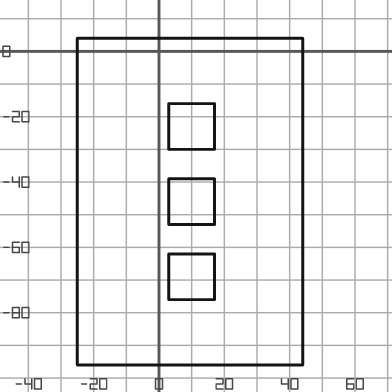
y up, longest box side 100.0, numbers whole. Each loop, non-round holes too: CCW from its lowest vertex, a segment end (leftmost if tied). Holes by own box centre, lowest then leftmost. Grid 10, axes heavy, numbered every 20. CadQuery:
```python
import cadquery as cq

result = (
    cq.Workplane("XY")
    .moveTo(-25.0, -96.0)
    .lineTo(44.0, -96.0)
    .lineTo(44.0, 4.0)
    .lineTo(-25.0, 4.0)
    .close()
    .moveTo(3.0, -76.0)
    .lineTo(17.0, -76.0)
    .lineTo(17.0, -62.0)
    .lineTo(3.0, -62.0)
    .close()
    .moveTo(3.0, -53.0)
    .lineTo(17.0, -53.0)
    .lineTo(17.0, -39.0)
    .lineTo(3.0, -39.0)
    .close()
    .moveTo(3.0, -30.0)
    .lineTo(17.0, -30.0)
    .lineTo(17.0, -16.0)
    .lineTo(3.0, -16.0)
    .close()
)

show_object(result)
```